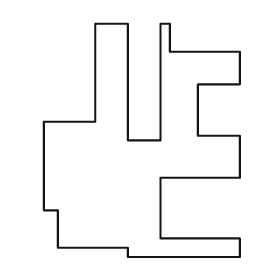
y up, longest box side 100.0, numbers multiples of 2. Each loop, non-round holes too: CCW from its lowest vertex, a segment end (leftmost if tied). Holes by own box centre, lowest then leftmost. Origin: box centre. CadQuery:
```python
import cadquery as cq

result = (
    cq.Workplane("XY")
    .moveTo(-6.0, -50.0)
    .lineTo(42.0, -50.0)
    .lineTo(42.0, -42.0)
    .lineTo(8.0, -42.0)
    .lineTo(8.0, -16.0)
    .lineTo(42.0, -16.0)
    .lineTo(42.0, 2.0)
    .lineTo(24.0, 2.0)
    .lineTo(24.0, 24.0)
    .lineTo(42.0, 24.0)
    .lineTo(42.0, 38.0)
    .lineTo(12.0, 38.0)
    .lineTo(12.0, 50.0)
    .lineTo(8.0, 50.0)
    .lineTo(8.0, 0.0)
    .lineTo(-6.0, 0.0)
    .lineTo(-6.0, 50.0)
    .lineTo(-20.0, 50.0)
    .lineTo(-20.0, 8.0)
    .lineTo(-42.0, 8.0)
    .lineTo(-42.0, -30.0)
    .lineTo(-36.0, -30.0)
    .lineTo(-36.0, -46.0)
    .lineTo(-6.0, -46.0)
    .close()
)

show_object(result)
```